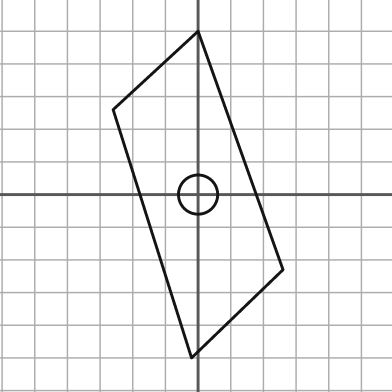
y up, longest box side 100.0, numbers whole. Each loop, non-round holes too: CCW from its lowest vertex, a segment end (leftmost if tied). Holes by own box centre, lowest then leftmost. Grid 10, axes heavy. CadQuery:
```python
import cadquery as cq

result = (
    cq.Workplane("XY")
    .moveTo(-2.0, -50.0)
    .lineTo(26.0, -23.0)
    .lineTo(0.0, 50.0)
    .lineTo(-26.0, 26.0)
    .close()
    .moveTo(0.0, 0.0)
    .circle(6.0)
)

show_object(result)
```